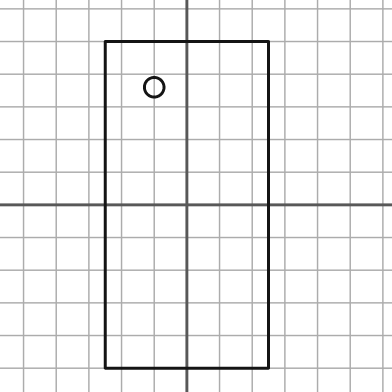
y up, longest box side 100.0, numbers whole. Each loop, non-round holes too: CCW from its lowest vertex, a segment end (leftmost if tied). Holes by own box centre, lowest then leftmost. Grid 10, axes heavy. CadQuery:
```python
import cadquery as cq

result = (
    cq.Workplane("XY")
    .moveTo(-25.0, -50.0)
    .lineTo(25.0, -50.0)
    .lineTo(25.0, 50.0)
    .lineTo(-25.0, 50.0)
    .close()
    .moveTo(-10.0, 36.0)
    .circle(3.0)
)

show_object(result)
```